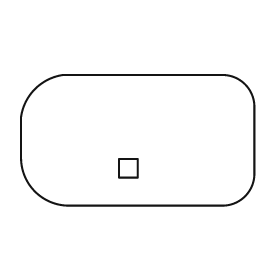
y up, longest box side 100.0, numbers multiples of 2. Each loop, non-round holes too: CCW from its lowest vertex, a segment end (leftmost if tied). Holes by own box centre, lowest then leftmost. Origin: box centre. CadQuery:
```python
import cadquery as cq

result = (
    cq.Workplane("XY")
    .moveTo(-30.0, -28.0)
    .lineTo(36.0, -28.0)
    .threePointArc((46.0, -24.0), (50.0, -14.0))
    .lineTo(50.0, 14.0)
    .threePointArc((46.0, 24.0), (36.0, 28.0))
    .lineTo(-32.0, 28.0)
    .threePointArc((-44.0, 22.0), (-50.0, 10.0))
    .lineTo(-50.0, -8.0)
    .threePointArc((-44.0, -22.0), (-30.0, -28.0))
    .close()
    .moveTo(-8.0, -16.0)
    .lineTo(0.0, -16.0)
    .lineTo(0.0, -8.0)
    .lineTo(-8.0, -8.0)
    .close()
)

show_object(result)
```